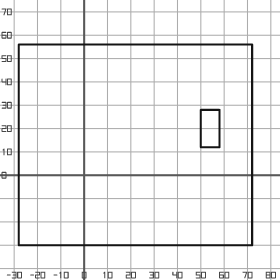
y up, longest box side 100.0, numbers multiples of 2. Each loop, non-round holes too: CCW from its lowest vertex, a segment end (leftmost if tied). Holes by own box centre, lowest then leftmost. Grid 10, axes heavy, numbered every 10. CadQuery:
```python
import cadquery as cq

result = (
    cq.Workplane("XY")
    .moveTo(-28.0, -30.0)
    .lineTo(72.0, -30.0)
    .lineTo(72.0, 56.0)
    .lineTo(-28.0, 56.0)
    .close()
    .moveTo(50.0, 12.0)
    .lineTo(58.0, 12.0)
    .lineTo(58.0, 28.0)
    .lineTo(50.0, 28.0)
    .close()
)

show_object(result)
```